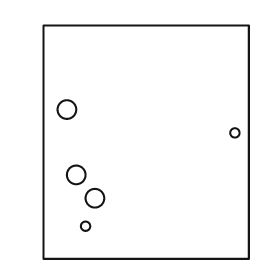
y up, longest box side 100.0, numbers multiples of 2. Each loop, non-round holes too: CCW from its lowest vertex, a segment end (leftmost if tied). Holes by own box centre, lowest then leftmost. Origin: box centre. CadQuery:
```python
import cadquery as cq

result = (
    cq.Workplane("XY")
    .moveTo(-44.0, -50.0)
    .lineTo(44.0, -50.0)
    .lineTo(44.0, 50.0)
    .lineTo(-44.0, 50.0)
    .close()
    .moveTo(-26.0, -36.0)
    .circle(2.0)
    .moveTo(-22.0, -24.0)
    .circle(4.0)
    .moveTo(-30.0, -14.0)
    .circle(4.0)
    .moveTo(38.0, 4.0)
    .circle(2.0)
    .moveTo(-34.0, 14.0)
    .circle(4.0)
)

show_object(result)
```